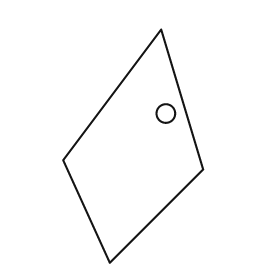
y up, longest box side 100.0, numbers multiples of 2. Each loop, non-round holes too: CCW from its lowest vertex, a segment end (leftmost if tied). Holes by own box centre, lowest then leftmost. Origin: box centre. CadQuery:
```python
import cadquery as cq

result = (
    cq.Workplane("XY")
    .moveTo(-10.0, -50.0)
    .lineTo(30.0, -10.0)
    .lineTo(12.0, 50.0)
    .lineTo(-30.0, -6.0)
    .close()
    .moveTo(14.0, 14.0)
    .circle(4.0)
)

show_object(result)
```